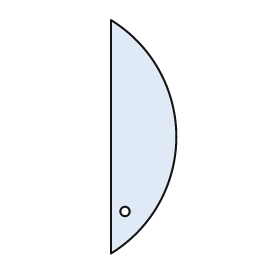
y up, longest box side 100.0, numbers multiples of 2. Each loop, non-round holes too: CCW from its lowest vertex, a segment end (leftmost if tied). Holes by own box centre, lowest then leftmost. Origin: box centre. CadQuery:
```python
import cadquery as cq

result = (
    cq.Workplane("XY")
    .moveTo(-14.0, -50.0)
    .threePointArc((14.0, 0.0), (-14.0, 50.0))
    .close()
    .moveTo(-8.0, -32.0)
    .circle(2.0)
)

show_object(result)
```